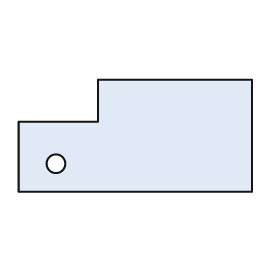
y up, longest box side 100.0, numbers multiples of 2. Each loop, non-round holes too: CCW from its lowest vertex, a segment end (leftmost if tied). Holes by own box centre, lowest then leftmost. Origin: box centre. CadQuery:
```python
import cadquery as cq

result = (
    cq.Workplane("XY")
    .moveTo(-50.0, -24.0)
    .lineTo(50.0, -24.0)
    .lineTo(50.0, 24.0)
    .lineTo(-16.0, 24.0)
    .lineTo(-16.0, 6.0)
    .lineTo(-50.0, 6.0)
    .close()
    .moveTo(-34.0, -12.0)
    .circle(4.0)
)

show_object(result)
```